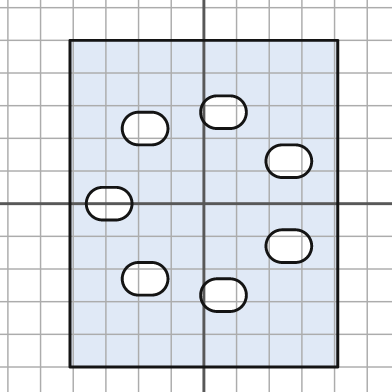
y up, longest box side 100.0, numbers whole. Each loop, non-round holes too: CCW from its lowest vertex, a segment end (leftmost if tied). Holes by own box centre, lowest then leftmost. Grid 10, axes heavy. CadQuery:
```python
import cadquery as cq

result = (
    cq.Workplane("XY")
    .moveTo(-41.0, -50.0)
    .lineTo(41.0, -50.0)
    .lineTo(41.0, 50.0)
    .lineTo(-41.0, 50.0)
    .close()
    .moveTo(4.0, -33.0)
    .lineTo(8.0, -33.0)
    .threePointArc((13.0, -28.0), (8.0, -23.0))
    .lineTo(4.0, -23.0)
    .threePointArc((-1.0, -28.0), (4.0, -33.0))
    .close()
    .moveTo(-20.0, -28.0)
    .lineTo(-16.0, -28.0)
    .threePointArc((-11.0, -23.0), (-16.0, -18.0))
    .lineTo(-20.0, -18.0)
    .threePointArc((-25.0, -23.0), (-20.0, -28.0))
    .close()
    .moveTo(24.0, -18.0)
    .lineTo(28.0, -18.0)
    .threePointArc((33.0, -13.0), (28.0, -8.0))
    .lineTo(24.0, -8.0)
    .threePointArc((19.0, -13.0), (24.0, -18.0))
    .close()
    .moveTo(-31.0, -5.0)
    .lineTo(-27.0, -5.0)
    .threePointArc((-22.0, 0.0), (-27.0, 5.0))
    .lineTo(-31.0, 5.0)
    .threePointArc((-36.0, 0.0), (-31.0, -5.0))
    .close()
    .moveTo(24.0, 8.0)
    .lineTo(28.0, 8.0)
    .threePointArc((33.0, 13.0), (28.0, 18.0))
    .lineTo(24.0, 18.0)
    .threePointArc((19.0, 13.0), (24.0, 8.0))
    .close()
    .moveTo(-20.0, 18.0)
    .lineTo(-16.0, 18.0)
    .threePointArc((-11.0, 23.0), (-16.0, 28.0))
    .lineTo(-20.0, 28.0)
    .threePointArc((-25.0, 23.0), (-20.0, 18.0))
    .close()
    .moveTo(4.0, 23.0)
    .lineTo(8.0, 23.0)
    .threePointArc((13.0, 28.0), (8.0, 33.0))
    .lineTo(4.0, 33.0)
    .threePointArc((-1.0, 28.0), (4.0, 23.0))
    .close()
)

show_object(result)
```